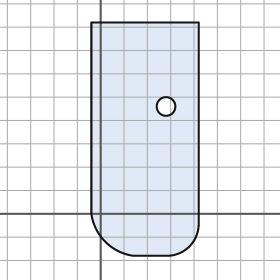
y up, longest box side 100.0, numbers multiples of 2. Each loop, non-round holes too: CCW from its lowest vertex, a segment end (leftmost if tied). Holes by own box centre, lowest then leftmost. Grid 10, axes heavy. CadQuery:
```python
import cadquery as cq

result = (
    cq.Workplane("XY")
    .moveTo(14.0, -18.0)
    .lineTo(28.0, -18.0)
    .threePointArc((38.0, -14.0), (42.0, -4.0))
    .lineTo(42.0, 82.0)
    .lineTo(-4.0, 82.0)
    .lineTo(-4.0, 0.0)
    .threePointArc((2.0, -12.0), (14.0, -18.0))
    .close()
    .moveTo(28.0, 46.0)
    .circle(4.0)
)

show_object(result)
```